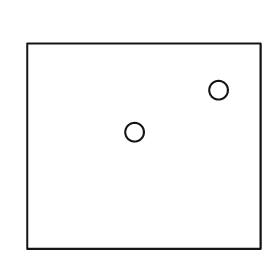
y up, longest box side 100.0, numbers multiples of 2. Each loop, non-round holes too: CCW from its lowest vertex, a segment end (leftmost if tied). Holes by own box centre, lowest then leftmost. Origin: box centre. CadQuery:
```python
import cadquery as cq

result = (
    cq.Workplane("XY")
    .moveTo(-50.0, -44.0)
    .lineTo(50.0, -44.0)
    .lineTo(50.0, 44.0)
    .lineTo(-50.0, 44.0)
    .close()
    .moveTo(-4.0, 6.0)
    .circle(4.0)
    .moveTo(32.0, 24.0)
    .circle(4.0)
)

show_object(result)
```